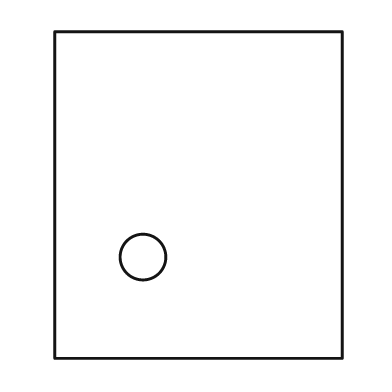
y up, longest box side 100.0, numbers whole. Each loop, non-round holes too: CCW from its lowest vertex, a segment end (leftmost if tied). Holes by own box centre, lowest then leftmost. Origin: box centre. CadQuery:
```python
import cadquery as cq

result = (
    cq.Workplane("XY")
    .moveTo(-44.0, -50.0)
    .lineTo(44.0, -50.0)
    .lineTo(44.0, 50.0)
    .lineTo(-44.0, 50.0)
    .close()
    .moveTo(-17.0, -19.0)
    .circle(7.0)
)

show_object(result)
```